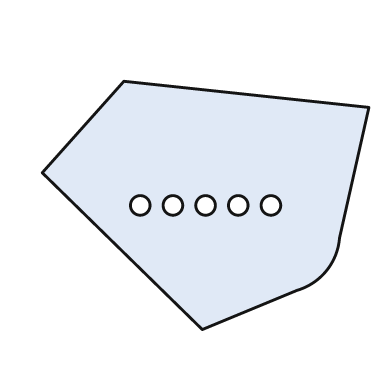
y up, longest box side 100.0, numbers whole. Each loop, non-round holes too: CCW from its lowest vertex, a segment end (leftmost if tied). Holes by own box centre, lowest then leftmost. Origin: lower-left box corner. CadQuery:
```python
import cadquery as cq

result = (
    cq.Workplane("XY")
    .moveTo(49.0, 0.0)
    .lineTo(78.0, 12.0)
    .threePointArc((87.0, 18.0), (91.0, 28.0))
    .lineTo(100.0, 68.0)
    .lineTo(25.0, 76.0)
    .lineTo(0.0, 48.0)
    .close()
    .moveTo(30.0, 38.0)
    .circle(3.0)
    .moveTo(40.0, 38.0)
    .circle(3.0)
    .moveTo(50.0, 38.0)
    .circle(3.0)
    .moveTo(60.0, 38.0)
    .circle(3.0)
    .moveTo(70.0, 38.0)
    .circle(3.0)
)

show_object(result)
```